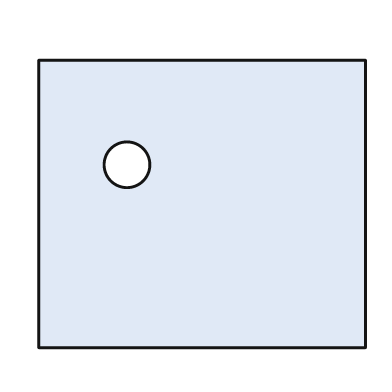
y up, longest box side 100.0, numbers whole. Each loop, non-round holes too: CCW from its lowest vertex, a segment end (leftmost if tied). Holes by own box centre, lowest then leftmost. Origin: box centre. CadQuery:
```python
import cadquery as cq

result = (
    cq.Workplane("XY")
    .moveTo(-50.0, -44.0)
    .lineTo(50.0, -44.0)
    .lineTo(50.0, 44.0)
    .lineTo(-50.0, 44.0)
    .close()
    .moveTo(-23.0, 12.0)
    .circle(7.0)
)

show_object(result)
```